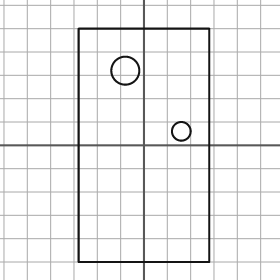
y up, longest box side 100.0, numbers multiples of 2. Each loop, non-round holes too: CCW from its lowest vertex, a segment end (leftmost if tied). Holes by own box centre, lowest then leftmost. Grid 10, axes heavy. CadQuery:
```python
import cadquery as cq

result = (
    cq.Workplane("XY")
    .moveTo(-28.0, -50.0)
    .lineTo(28.0, -50.0)
    .lineTo(28.0, 50.0)
    .lineTo(-28.0, 50.0)
    .close()
    .moveTo(16.0, 6.0)
    .circle(4.0)
    .moveTo(-8.0, 32.0)
    .circle(6.0)
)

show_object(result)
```